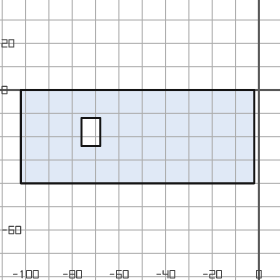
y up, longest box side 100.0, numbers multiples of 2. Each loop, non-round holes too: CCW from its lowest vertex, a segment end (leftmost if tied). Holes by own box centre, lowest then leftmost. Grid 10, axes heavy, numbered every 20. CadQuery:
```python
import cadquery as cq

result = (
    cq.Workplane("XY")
    .moveTo(-102.0, -40.0)
    .lineTo(-2.0, -40.0)
    .lineTo(-2.0, 0.0)
    .lineTo(-102.0, 0.0)
    .close()
    .moveTo(-76.0, -24.0)
    .lineTo(-68.0, -24.0)
    .lineTo(-68.0, -12.0)
    .lineTo(-76.0, -12.0)
    .close()
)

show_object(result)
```